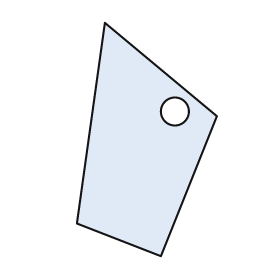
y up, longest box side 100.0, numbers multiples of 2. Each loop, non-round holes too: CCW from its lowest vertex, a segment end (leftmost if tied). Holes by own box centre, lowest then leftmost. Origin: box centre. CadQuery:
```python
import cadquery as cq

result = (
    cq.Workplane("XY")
    .moveTo(6.0, -50.0)
    .lineTo(30.0, 10.0)
    .lineTo(-18.0, 50.0)
    .lineTo(-30.0, -36.0)
    .close()
    .moveTo(12.0, 12.0)
    .circle(6.0)
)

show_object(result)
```